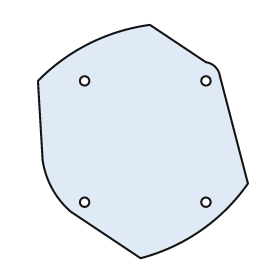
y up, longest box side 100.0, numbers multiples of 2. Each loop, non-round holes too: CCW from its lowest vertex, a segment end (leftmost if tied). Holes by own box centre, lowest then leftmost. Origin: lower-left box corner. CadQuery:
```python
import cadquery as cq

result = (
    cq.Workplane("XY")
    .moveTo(44.0, 0.0)
    .threePointArc((70.0, 12.0), (90.0, 32.0))
    .lineTo(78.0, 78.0)
    .threePointArc((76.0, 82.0), (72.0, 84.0))
    .lineTo(48.0, 100.0)
    .threePointArc((22.0, 92.0), (0.0, 76.0))
    .lineTo(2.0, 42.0)
    .threePointArc((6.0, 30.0), (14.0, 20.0))
    .close()
    .moveTo(20.0, 24.0)
    .circle(2.0)
    .moveTo(72.0, 24.0)
    .circle(2.0)
    .moveTo(20.0, 76.0)
    .circle(2.0)
    .moveTo(72.0, 76.0)
    .circle(2.0)
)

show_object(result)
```